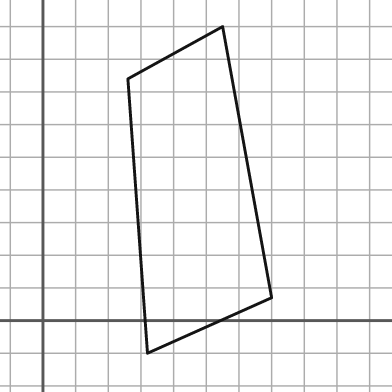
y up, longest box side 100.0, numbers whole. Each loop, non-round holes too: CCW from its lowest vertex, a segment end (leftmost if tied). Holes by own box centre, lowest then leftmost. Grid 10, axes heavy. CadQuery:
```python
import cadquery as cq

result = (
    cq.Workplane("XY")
    .moveTo(32.0, -10.0)
    .lineTo(70.0, 7.0)
    .lineTo(55.0, 90.0)
    .lineTo(26.0, 74.0)
    .close()
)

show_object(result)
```